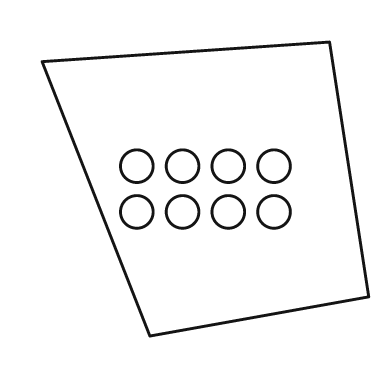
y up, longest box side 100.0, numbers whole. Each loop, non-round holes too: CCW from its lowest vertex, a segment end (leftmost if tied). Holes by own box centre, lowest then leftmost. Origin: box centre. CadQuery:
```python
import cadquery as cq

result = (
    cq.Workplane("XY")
    .moveTo(-17.0, -45.0)
    .lineTo(50.0, -33.0)
    .lineTo(38.0, 45.0)
    .lineTo(-50.0, 39.0)
    .close()
    .moveTo(-21.0, -7.0)
    .circle(5.0)
    .moveTo(-7.0, -7.0)
    .circle(5.0)
    .moveTo(7.0, -7.0)
    .circle(5.0)
    .moveTo(21.0, -7.0)
    .circle(5.0)
    .moveTo(-21.0, 7.0)
    .circle(5.0)
    .moveTo(-7.0, 7.0)
    .circle(5.0)
    .moveTo(7.0, 7.0)
    .circle(5.0)
    .moveTo(21.0, 7.0)
    .circle(5.0)
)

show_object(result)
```